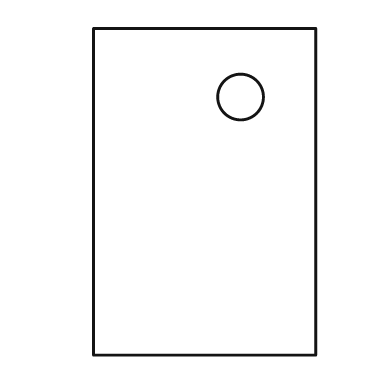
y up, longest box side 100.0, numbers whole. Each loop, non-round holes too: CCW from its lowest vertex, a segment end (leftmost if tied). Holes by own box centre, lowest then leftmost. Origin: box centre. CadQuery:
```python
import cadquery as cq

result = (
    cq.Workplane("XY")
    .moveTo(-34.0, -50.0)
    .lineTo(34.0, -50.0)
    .lineTo(34.0, 50.0)
    .lineTo(-34.0, 50.0)
    .close()
    .moveTo(11.0, 29.0)
    .circle(7.0)
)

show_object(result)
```